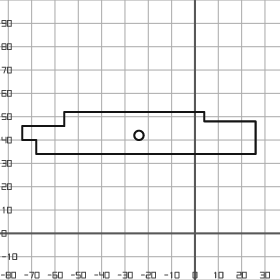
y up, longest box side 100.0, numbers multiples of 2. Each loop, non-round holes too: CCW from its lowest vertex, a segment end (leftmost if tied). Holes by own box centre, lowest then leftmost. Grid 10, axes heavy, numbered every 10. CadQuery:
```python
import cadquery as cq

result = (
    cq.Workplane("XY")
    .moveTo(-68.0, 34.0)
    .lineTo(26.0, 34.0)
    .lineTo(26.0, 48.0)
    .lineTo(4.0, 48.0)
    .lineTo(4.0, 52.0)
    .lineTo(-56.0, 52.0)
    .lineTo(-56.0, 46.0)
    .lineTo(-74.0, 46.0)
    .lineTo(-74.0, 40.0)
    .lineTo(-68.0, 40.0)
    .close()
    .moveTo(-24.0, 42.0)
    .circle(2.0)
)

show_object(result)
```